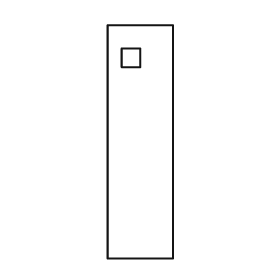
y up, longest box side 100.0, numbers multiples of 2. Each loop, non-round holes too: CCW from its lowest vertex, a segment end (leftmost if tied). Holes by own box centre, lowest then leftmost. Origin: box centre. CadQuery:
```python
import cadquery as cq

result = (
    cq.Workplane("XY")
    .moveTo(-14.0, -50.0)
    .lineTo(14.0, -50.0)
    .lineTo(14.0, 50.0)
    .lineTo(-14.0, 50.0)
    .close()
    .moveTo(-8.0, 32.0)
    .lineTo(0.0, 32.0)
    .lineTo(0.0, 40.0)
    .lineTo(-8.0, 40.0)
    .close()
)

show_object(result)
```